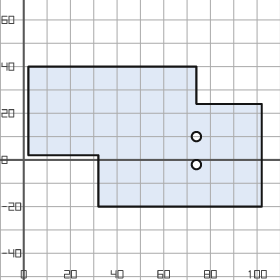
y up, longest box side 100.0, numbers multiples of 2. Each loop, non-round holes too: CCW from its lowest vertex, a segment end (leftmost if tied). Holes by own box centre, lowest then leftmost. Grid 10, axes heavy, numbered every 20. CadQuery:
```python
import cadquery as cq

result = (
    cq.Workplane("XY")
    .moveTo(32.0, -20.0)
    .lineTo(102.0, -20.0)
    .lineTo(102.0, 24.0)
    .lineTo(74.0, 24.0)
    .lineTo(74.0, 40.0)
    .lineTo(2.0, 40.0)
    .lineTo(2.0, 2.0)
    .lineTo(32.0, 2.0)
    .close()
    .moveTo(74.0, -2.0)
    .circle(2.0)
    .moveTo(74.0, 10.0)
    .circle(2.0)
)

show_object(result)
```